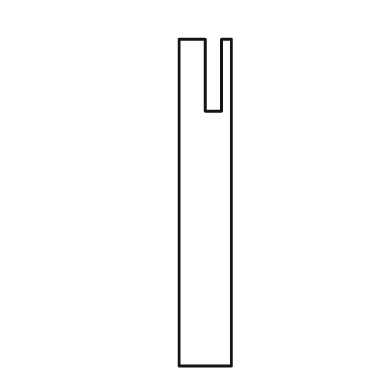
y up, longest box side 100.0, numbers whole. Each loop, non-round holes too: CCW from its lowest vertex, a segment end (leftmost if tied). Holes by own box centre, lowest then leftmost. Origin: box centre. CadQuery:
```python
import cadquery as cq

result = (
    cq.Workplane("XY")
    .moveTo(-8.0, -50.0)
    .lineTo(8.0, -50.0)
    .lineTo(8.0, 50.0)
    .lineTo(5.0, 50.0)
    .lineTo(5.0, 28.0)
    .lineTo(0.0, 28.0)
    .lineTo(0.0, 50.0)
    .lineTo(-8.0, 50.0)
    .close()
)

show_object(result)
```